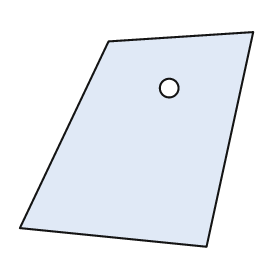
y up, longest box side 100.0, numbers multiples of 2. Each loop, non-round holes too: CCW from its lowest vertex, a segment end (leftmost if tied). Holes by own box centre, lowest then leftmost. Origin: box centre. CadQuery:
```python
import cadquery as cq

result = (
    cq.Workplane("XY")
    .moveTo(30.0, -46.0)
    .lineTo(50.0, 46.0)
    .lineTo(-12.0, 42.0)
    .lineTo(-50.0, -38.0)
    .close()
    .moveTo(14.0, 22.0)
    .circle(4.0)
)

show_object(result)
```